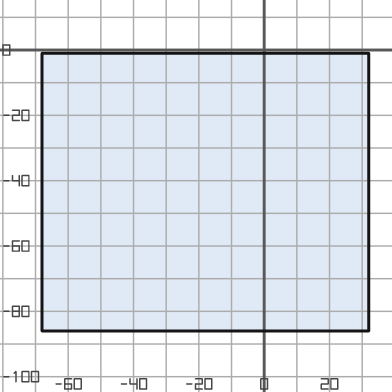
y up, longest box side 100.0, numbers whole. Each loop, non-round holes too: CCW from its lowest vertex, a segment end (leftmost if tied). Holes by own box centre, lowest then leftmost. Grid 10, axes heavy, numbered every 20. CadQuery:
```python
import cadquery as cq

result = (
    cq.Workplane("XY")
    .moveTo(-68.0, -86.0)
    .lineTo(32.0, -86.0)
    .lineTo(32.0, -1.0)
    .lineTo(-68.0, -1.0)
    .close()
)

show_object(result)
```